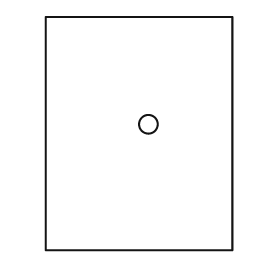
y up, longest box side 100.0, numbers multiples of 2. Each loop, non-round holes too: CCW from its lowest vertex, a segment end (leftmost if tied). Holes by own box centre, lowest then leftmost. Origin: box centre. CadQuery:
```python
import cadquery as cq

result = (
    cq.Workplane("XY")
    .moveTo(-40.0, -50.0)
    .lineTo(40.0, -50.0)
    .lineTo(40.0, 50.0)
    .lineTo(-40.0, 50.0)
    .close()
    .moveTo(4.0, 4.0)
    .circle(4.0)
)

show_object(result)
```